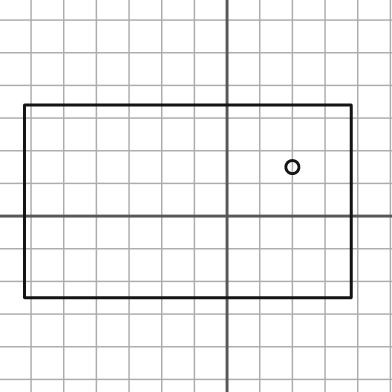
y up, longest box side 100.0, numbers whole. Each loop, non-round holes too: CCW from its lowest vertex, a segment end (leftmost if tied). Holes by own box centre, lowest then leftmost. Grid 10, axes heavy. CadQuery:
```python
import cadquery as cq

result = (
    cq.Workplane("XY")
    .moveTo(-62.0, -25.0)
    .lineTo(38.0, -25.0)
    .lineTo(38.0, 34.0)
    .lineTo(-62.0, 34.0)
    .close()
    .moveTo(20.0, 15.0)
    .circle(2.0)
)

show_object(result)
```